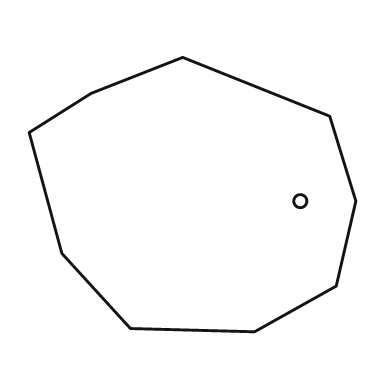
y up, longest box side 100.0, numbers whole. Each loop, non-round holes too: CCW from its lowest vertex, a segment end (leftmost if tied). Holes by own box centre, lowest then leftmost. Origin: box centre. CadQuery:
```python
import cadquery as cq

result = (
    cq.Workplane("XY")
    .moveTo(19.0, -42.0)
    .lineTo(44.0, -28.0)
    .lineTo(50.0, -2.0)
    .lineTo(42.0, 24.0)
    .lineTo(-3.0, 42.0)
    .lineTo(-31.0, 31.0)
    .lineTo(-50.0, 19.0)
    .lineTo(-40.0, -18.0)
    .lineTo(-19.0, -41.0)
    .close()
    .moveTo(33.0, -2.0)
    .circle(2.0)
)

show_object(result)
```